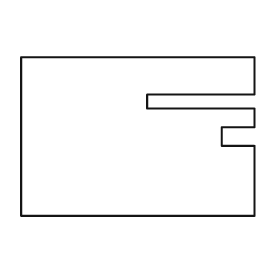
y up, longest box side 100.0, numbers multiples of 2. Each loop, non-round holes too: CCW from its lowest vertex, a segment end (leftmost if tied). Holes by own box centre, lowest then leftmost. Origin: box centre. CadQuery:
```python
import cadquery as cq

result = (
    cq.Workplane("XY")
    .moveTo(-50.0, -34.0)
    .lineTo(50.0, -34.0)
    .lineTo(50.0, -4.0)
    .lineTo(36.0, -4.0)
    .lineTo(36.0, 4.0)
    .lineTo(50.0, 4.0)
    .lineTo(50.0, 12.0)
    .lineTo(4.0, 12.0)
    .lineTo(4.0, 18.0)
    .lineTo(50.0, 18.0)
    .lineTo(50.0, 34.0)
    .lineTo(-50.0, 34.0)
    .close()
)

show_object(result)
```